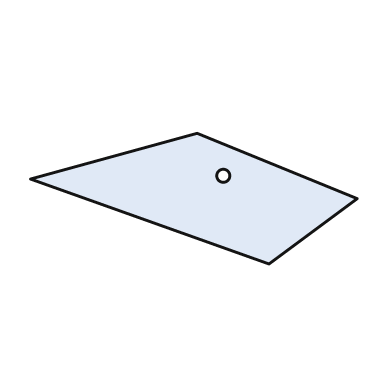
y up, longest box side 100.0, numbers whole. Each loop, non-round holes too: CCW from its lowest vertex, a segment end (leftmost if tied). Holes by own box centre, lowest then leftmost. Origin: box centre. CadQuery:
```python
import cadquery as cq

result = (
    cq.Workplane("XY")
    .moveTo(23.0, -20.0)
    .lineTo(50.0, 0.0)
    .lineTo(1.0, 20.0)
    .lineTo(-50.0, 6.0)
    .close()
    .moveTo(9.0, 7.0)
    .circle(2.0)
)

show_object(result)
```